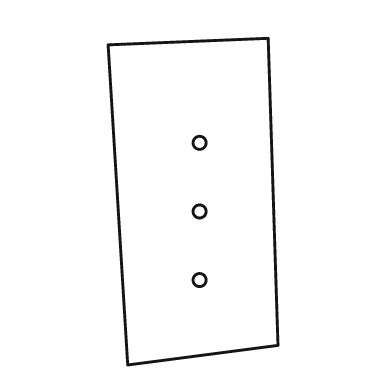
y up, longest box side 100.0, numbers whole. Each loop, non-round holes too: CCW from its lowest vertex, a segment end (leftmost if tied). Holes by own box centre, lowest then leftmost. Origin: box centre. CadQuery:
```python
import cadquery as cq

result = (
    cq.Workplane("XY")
    .moveTo(-20.0, -50.0)
    .lineTo(26.0, -44.0)
    .lineTo(23.0, 50.0)
    .lineTo(-26.0, 48.0)
    .close()
    .moveTo(2.0, -24.0)
    .circle(2.0)
    .moveTo(2.0, -3.0)
    .circle(2.0)
    .moveTo(2.0, 18.0)
    .circle(2.0)
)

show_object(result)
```